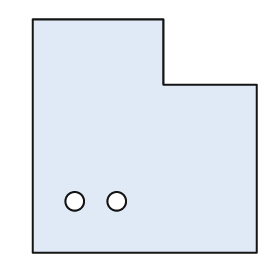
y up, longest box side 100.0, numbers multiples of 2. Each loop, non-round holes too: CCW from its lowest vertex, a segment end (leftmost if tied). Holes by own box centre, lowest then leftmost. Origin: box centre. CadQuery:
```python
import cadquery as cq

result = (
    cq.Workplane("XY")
    .moveTo(-48.0, -50.0)
    .lineTo(48.0, -50.0)
    .lineTo(48.0, 22.0)
    .lineTo(8.0, 22.0)
    .lineTo(8.0, 50.0)
    .lineTo(-48.0, 50.0)
    .close()
    .moveTo(-30.0, -28.0)
    .circle(4.0)
    .moveTo(-12.0, -28.0)
    .circle(4.0)
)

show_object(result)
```